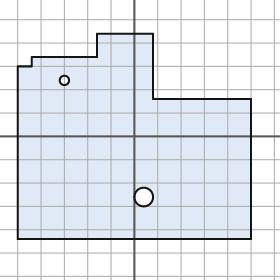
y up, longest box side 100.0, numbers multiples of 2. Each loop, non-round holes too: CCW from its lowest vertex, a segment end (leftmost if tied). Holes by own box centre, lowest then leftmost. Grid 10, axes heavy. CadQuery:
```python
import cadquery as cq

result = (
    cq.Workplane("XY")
    .moveTo(-50.0, -44.0)
    .lineTo(50.0, -44.0)
    .lineTo(50.0, 16.0)
    .lineTo(8.0, 16.0)
    .lineTo(8.0, 44.0)
    .lineTo(-16.0, 44.0)
    .lineTo(-16.0, 34.0)
    .lineTo(-44.0, 34.0)
    .lineTo(-44.0, 30.0)
    .lineTo(-50.0, 30.0)
    .close()
    .moveTo(4.0, -26.0)
    .circle(4.0)
    .moveTo(-30.0, 24.0)
    .circle(2.0)
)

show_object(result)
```